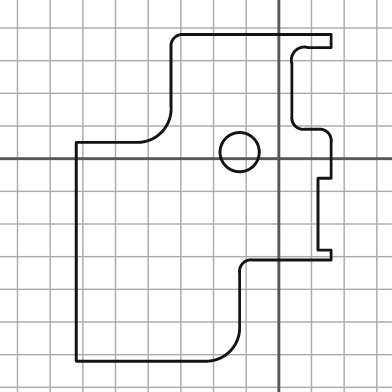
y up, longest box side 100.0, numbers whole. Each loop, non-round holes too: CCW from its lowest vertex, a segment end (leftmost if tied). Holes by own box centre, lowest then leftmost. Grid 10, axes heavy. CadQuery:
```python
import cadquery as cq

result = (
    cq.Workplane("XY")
    .moveTo(-62.0, -62.0)
    .lineTo(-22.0, -62.0)
    .threePointArc((-15.0, -59.0), (-12.0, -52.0))
    .lineTo(-12.0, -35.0)
    .threePointArc((-11.0, -32.0), (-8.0, -31.0))
    .lineTo(16.0, -31.0)
    .lineTo(16.0, -28.0)
    .lineTo(12.0, -28.0)
    .lineTo(12.0, -6.0)
    .lineTo(16.0, -6.0)
    .lineTo(16.0, 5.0)
    .threePointArc((15.0, 8.0), (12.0, 9.0))
    .lineTo(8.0, 9.0)
    .threePointArc((5.0, 10.0), (4.0, 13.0))
    .lineTo(4.0, 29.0)
    .threePointArc((5.0, 33.0), (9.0, 34.0))
    .lineTo(16.0, 34.0)
    .lineTo(16.0, 38.0)
    .lineTo(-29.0, 38.0)
    .threePointArc((-32.0, 37.0), (-33.0, 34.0))
    .lineTo(-33.0, 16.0)
    .threePointArc((-36.0, 8.0), (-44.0, 5.0))
    .lineTo(-62.0, 5.0)
    .close()
    .moveTo(-12.0, 2.0)
    .circle(6.0)
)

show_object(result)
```